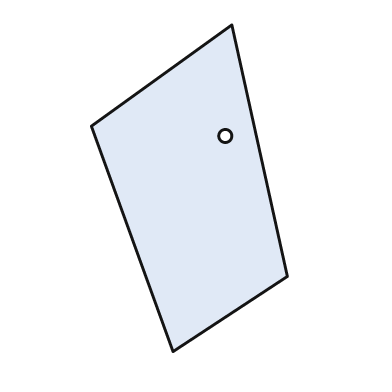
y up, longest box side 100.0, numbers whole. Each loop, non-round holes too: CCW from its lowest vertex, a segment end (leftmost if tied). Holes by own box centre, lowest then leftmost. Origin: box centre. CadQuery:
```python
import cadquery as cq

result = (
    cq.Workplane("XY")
    .moveTo(-5.0, -50.0)
    .lineTo(30.0, -27.0)
    .lineTo(13.0, 50.0)
    .lineTo(-30.0, 19.0)
    .close()
    .moveTo(11.0, 16.0)
    .circle(2.0)
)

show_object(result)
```